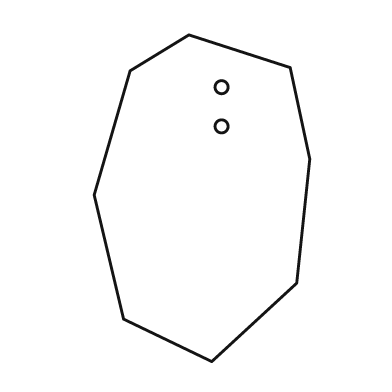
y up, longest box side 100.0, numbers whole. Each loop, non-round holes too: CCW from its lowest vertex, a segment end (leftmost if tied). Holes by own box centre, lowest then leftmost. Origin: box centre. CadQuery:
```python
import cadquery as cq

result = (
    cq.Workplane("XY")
    .moveTo(3.0, -50.0)
    .lineTo(29.0, -26.0)
    .lineTo(33.0, 12.0)
    .lineTo(27.0, 40.0)
    .lineTo(-4.0, 50.0)
    .lineTo(-22.0, 39.0)
    .lineTo(-33.0, 1.0)
    .lineTo(-24.0, -37.0)
    .close()
    .moveTo(6.0, 22.0)
    .circle(2.0)
    .moveTo(6.0, 34.0)
    .circle(2.0)
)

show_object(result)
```